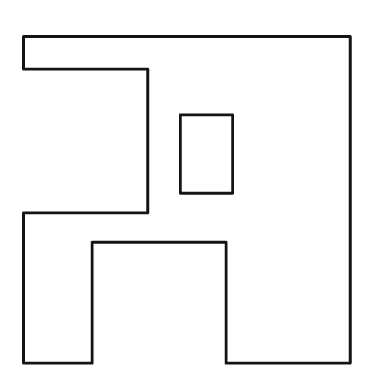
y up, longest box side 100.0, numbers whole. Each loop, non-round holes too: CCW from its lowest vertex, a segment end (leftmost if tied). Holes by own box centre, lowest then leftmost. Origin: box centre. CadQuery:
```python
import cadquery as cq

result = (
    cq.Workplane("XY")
    .moveTo(-50.0, -50.0)
    .lineTo(-29.0, -50.0)
    .lineTo(-29.0, -13.0)
    .lineTo(12.0, -13.0)
    .lineTo(12.0, -50.0)
    .lineTo(50.0, -50.0)
    .lineTo(50.0, 50.0)
    .lineTo(-50.0, 50.0)
    .lineTo(-50.0, 40.0)
    .lineTo(-12.0, 40.0)
    .lineTo(-12.0, -4.0)
    .lineTo(-50.0, -4.0)
    .close()
    .moveTo(-2.0, 2.0)
    .lineTo(14.0, 2.0)
    .lineTo(14.0, 26.0)
    .lineTo(-2.0, 26.0)
    .close()
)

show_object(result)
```